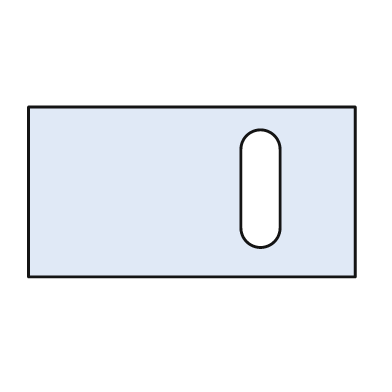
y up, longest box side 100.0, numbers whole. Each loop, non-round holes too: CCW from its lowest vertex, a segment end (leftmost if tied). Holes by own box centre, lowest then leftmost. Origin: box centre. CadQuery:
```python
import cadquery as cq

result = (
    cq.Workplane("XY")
    .moveTo(-50.0, -26.0)
    .lineTo(50.0, -26.0)
    .lineTo(50.0, 26.0)
    .lineTo(-50.0, 26.0)
    .close()
    .moveTo(15.0, -11.0)
    .threePointArc((21.0, -17.0), (27.0, -11.0))
    .lineTo(27.0, 13.0)
    .threePointArc((21.0, 19.0), (15.0, 13.0))
    .close()
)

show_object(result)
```